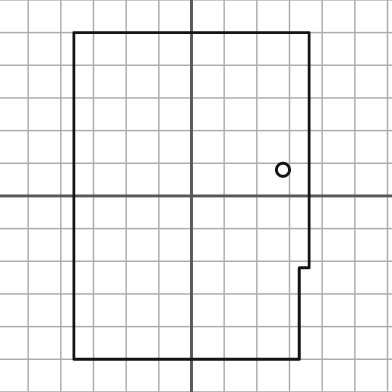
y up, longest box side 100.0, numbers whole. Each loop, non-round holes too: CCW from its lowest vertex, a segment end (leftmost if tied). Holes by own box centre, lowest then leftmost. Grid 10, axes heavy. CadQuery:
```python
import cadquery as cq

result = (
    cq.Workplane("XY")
    .moveTo(-36.0, -50.0)
    .lineTo(33.0, -50.0)
    .lineTo(33.0, -22.0)
    .lineTo(36.0, -22.0)
    .lineTo(36.0, 50.0)
    .lineTo(-36.0, 50.0)
    .close()
    .moveTo(28.0, 8.0)
    .circle(2.0)
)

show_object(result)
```